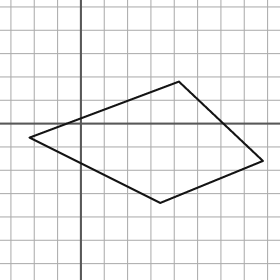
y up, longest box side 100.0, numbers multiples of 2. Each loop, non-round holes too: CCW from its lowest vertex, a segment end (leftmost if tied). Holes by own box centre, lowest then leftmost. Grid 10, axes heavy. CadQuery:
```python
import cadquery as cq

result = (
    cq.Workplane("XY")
    .moveTo(34.0, -34.0)
    .lineTo(78.0, -16.0)
    .lineTo(42.0, 18.0)
    .lineTo(-22.0, -6.0)
    .close()
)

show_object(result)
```